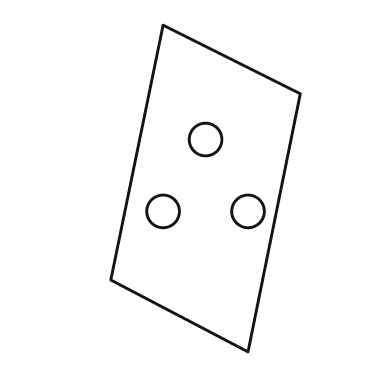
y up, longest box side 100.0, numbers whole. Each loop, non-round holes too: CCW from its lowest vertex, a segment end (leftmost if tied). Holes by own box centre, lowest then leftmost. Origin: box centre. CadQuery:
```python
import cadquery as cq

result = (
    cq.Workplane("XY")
    .moveTo(13.0, -50.0)
    .lineTo(29.0, 29.0)
    .lineTo(-13.0, 50.0)
    .lineTo(-29.0, -28.0)
    .close()
    .moveTo(-13.0, -7.0)
    .circle(5.0)
    .moveTo(13.0, -7.0)
    .circle(5.0)
    .moveTo(0.0, 15.0)
    .circle(5.0)
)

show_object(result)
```